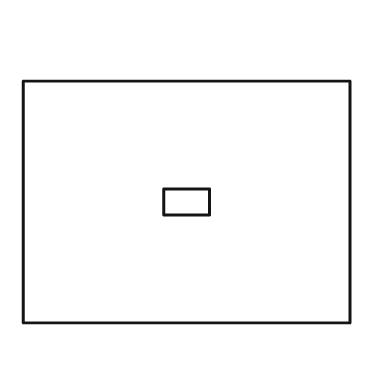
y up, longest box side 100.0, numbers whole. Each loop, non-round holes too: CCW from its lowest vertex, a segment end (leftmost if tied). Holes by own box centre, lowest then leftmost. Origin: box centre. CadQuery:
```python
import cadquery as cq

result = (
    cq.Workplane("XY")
    .moveTo(-50.0, -37.0)
    .lineTo(50.0, -37.0)
    .lineTo(50.0, 37.0)
    .lineTo(-50.0, 37.0)
    .close()
    .moveTo(-7.0, -4.0)
    .lineTo(7.0, -4.0)
    .lineTo(7.0, 4.0)
    .lineTo(-7.0, 4.0)
    .close()
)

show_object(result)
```